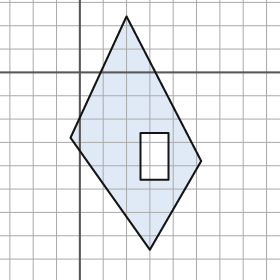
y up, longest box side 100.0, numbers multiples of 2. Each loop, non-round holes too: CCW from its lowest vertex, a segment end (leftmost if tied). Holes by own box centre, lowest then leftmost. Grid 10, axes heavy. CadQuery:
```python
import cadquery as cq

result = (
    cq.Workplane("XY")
    .moveTo(30.0, -76.0)
    .lineTo(52.0, -38.0)
    .lineTo(20.0, 24.0)
    .lineTo(-4.0, -28.0)
    .close()
    .moveTo(26.0, -46.0)
    .lineTo(38.0, -46.0)
    .lineTo(38.0, -26.0)
    .lineTo(26.0, -26.0)
    .close()
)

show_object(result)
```